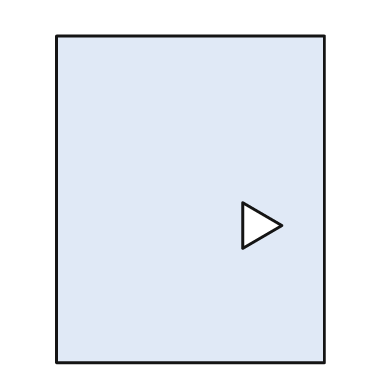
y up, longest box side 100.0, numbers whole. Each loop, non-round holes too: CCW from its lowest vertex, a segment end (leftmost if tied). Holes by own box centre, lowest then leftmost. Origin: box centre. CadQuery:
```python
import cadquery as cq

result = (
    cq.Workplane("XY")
    .moveTo(-41.0, -50.0)
    .lineTo(41.0, -50.0)
    .lineTo(41.0, 50.0)
    .lineTo(-41.0, 50.0)
    .close()
    .moveTo(16.0, -15.0)
    .lineTo(28.0, -8.0)
    .lineTo(16.0, -1.0)
    .close()
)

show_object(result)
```